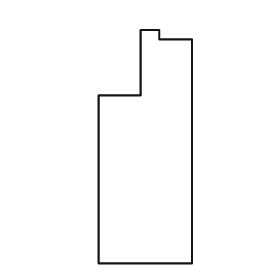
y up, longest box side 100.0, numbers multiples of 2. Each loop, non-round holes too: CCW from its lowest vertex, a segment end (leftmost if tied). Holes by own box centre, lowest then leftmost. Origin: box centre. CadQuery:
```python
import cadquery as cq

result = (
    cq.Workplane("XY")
    .moveTo(-20.0, -50.0)
    .lineTo(20.0, -50.0)
    .lineTo(20.0, 46.0)
    .lineTo(6.0, 46.0)
    .lineTo(6.0, 50.0)
    .lineTo(-2.0, 50.0)
    .lineTo(-2.0, 22.0)
    .lineTo(-20.0, 22.0)
    .close()
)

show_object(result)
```